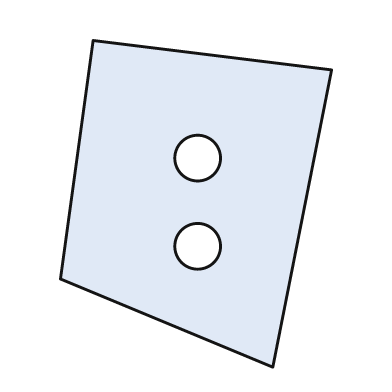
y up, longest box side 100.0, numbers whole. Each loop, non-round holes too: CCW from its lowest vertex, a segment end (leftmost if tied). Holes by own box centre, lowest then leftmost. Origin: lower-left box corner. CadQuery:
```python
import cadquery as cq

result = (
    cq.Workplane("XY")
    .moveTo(65.0, 0.0)
    .lineTo(83.0, 91.0)
    .lineTo(10.0, 100.0)
    .lineTo(0.0, 27.0)
    .close()
    .moveTo(42.0, 37.0)
    .circle(7.0)
    .moveTo(42.0, 64.0)
    .circle(7.0)
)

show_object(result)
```